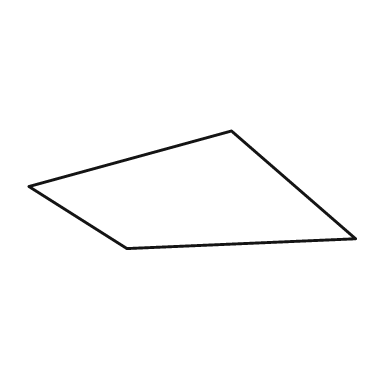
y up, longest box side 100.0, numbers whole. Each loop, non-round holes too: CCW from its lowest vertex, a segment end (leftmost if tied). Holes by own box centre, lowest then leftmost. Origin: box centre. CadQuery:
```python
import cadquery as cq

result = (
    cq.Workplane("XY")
    .moveTo(-20.0, -18.0)
    .lineTo(50.0, -15.0)
    .lineTo(12.0, 18.0)
    .lineTo(-50.0, 1.0)
    .close()
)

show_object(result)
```